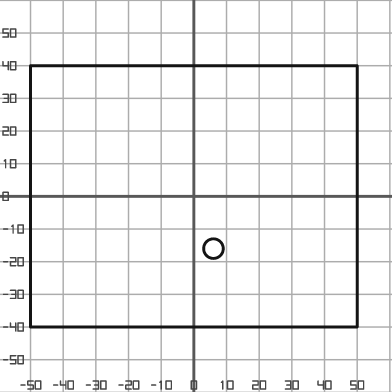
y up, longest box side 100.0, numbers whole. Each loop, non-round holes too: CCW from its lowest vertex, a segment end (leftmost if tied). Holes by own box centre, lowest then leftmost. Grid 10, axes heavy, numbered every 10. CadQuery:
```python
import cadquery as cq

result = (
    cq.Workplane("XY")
    .moveTo(-50.0, -40.0)
    .lineTo(50.0, -40.0)
    .lineTo(50.0, 40.0)
    .lineTo(-50.0, 40.0)
    .close()
    .moveTo(6.0, -16.0)
    .circle(3.0)
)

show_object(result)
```